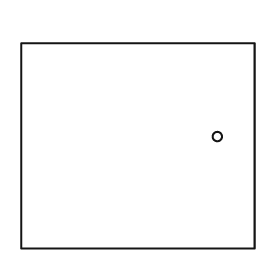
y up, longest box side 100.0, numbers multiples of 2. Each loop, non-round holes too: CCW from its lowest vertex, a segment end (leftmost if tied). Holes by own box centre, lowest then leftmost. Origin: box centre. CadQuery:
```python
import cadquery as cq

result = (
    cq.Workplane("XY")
    .moveTo(-50.0, -44.0)
    .lineTo(50.0, -44.0)
    .lineTo(50.0, 44.0)
    .lineTo(-50.0, 44.0)
    .close()
    .moveTo(34.0, 4.0)
    .circle(2.0)
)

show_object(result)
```